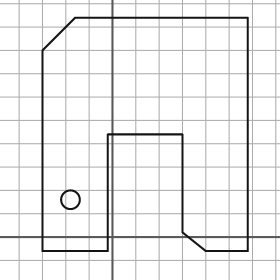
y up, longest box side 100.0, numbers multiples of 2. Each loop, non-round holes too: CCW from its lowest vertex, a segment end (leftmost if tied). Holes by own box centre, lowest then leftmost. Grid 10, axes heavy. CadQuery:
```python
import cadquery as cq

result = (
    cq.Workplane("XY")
    .moveTo(-30.0, -6.0)
    .lineTo(-2.0, -6.0)
    .lineTo(-2.0, 44.0)
    .lineTo(30.0, 44.0)
    .lineTo(30.0, 2.0)
    .lineTo(40.0, -6.0)
    .lineTo(58.0, -6.0)
    .lineTo(58.0, 94.0)
    .lineTo(-16.0, 94.0)
    .lineTo(-30.0, 80.0)
    .close()
    .moveTo(-18.0, 16.0)
    .circle(4.0)
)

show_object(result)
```